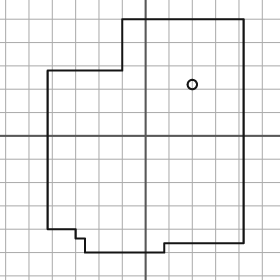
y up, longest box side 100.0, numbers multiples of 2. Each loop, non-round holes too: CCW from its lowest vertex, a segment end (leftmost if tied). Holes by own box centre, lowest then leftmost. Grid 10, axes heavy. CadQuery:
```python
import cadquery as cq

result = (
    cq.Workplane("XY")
    .moveTo(-26.0, -50.0)
    .lineTo(8.0, -50.0)
    .lineTo(8.0, -46.0)
    .lineTo(42.0, -46.0)
    .lineTo(42.0, 50.0)
    .lineTo(-10.0, 50.0)
    .lineTo(-10.0, 28.0)
    .lineTo(-42.0, 28.0)
    .lineTo(-42.0, -40.0)
    .lineTo(-30.0, -40.0)
    .lineTo(-30.0, -44.0)
    .lineTo(-26.0, -44.0)
    .close()
    .moveTo(20.0, 22.0)
    .circle(2.0)
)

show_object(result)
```